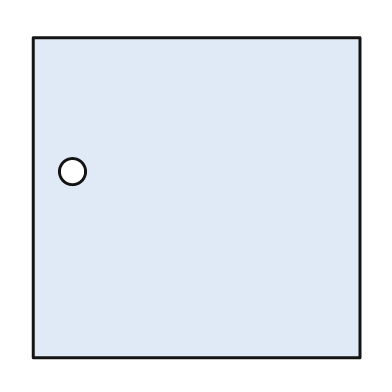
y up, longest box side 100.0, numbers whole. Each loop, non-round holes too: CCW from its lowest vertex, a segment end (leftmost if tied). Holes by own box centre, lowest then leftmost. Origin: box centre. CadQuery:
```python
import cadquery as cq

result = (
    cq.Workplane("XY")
    .moveTo(-50.0, -49.0)
    .lineTo(50.0, -49.0)
    .lineTo(50.0, 49.0)
    .lineTo(-50.0, 49.0)
    .close()
    .moveTo(-38.0, 8.0)
    .circle(4.0)
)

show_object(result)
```